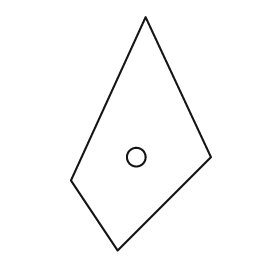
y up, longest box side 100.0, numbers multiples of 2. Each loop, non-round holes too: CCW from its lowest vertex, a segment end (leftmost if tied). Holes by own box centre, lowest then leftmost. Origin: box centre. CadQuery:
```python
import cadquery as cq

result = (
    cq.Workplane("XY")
    .moveTo(-10.0, -50.0)
    .lineTo(30.0, -10.0)
    .lineTo(2.0, 50.0)
    .lineTo(-30.0, -20.0)
    .close()
    .moveTo(-2.0, -10.0)
    .circle(4.0)
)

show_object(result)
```